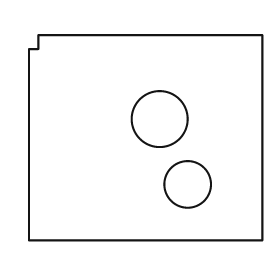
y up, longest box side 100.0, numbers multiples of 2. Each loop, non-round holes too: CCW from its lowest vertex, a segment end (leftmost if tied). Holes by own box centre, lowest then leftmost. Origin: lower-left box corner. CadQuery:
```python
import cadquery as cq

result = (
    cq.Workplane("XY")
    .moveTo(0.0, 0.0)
    .lineTo(100.0, 0.0)
    .lineTo(100.0, 88.0)
    .lineTo(4.0, 88.0)
    .lineTo(4.0, 82.0)
    .lineTo(0.0, 82.0)
    .close()
    .moveTo(68.0, 24.0)
    .circle(10.0)
    .moveTo(56.0, 52.0)
    .circle(12.0)
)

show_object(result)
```